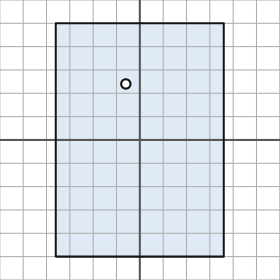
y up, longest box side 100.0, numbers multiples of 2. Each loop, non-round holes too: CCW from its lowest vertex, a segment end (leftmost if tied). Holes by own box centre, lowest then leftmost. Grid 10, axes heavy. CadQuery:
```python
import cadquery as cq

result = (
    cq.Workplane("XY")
    .moveTo(-36.0, -50.0)
    .lineTo(36.0, -50.0)
    .lineTo(36.0, 50.0)
    .lineTo(-36.0, 50.0)
    .close()
    .moveTo(-6.0, 24.0)
    .circle(2.0)
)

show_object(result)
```